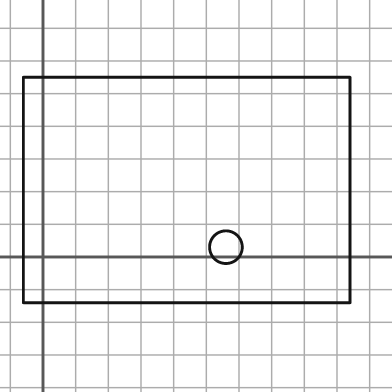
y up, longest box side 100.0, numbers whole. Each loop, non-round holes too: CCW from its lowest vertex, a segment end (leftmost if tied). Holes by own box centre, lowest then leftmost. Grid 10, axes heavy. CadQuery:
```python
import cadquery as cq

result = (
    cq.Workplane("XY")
    .moveTo(-6.0, -14.0)
    .lineTo(94.0, -14.0)
    .lineTo(94.0, 55.0)
    .lineTo(-6.0, 55.0)
    .close()
    .moveTo(56.0, 3.0)
    .circle(5.0)
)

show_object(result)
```